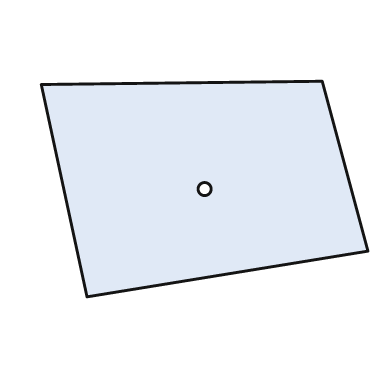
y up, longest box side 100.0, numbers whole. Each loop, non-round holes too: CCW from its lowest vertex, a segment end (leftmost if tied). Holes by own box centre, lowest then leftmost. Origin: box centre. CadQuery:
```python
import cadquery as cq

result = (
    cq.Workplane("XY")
    .moveTo(-36.0, -33.0)
    .lineTo(50.0, -19.0)
    .lineTo(36.0, 33.0)
    .lineTo(-50.0, 32.0)
    .close()
    .moveTo(0.0, 0.0)
    .circle(2.0)
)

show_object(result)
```